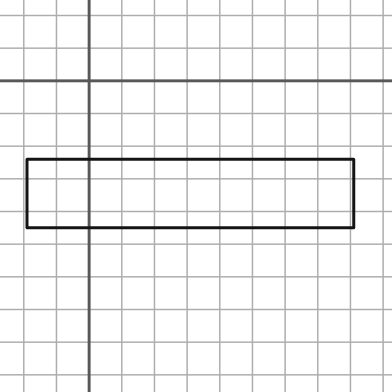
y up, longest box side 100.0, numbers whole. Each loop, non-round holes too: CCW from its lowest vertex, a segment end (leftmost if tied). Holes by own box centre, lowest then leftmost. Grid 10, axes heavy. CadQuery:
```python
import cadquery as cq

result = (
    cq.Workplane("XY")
    .moveTo(-19.0, -45.0)
    .lineTo(81.0, -45.0)
    .lineTo(81.0, -24.0)
    .lineTo(-19.0, -24.0)
    .close()
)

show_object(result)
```